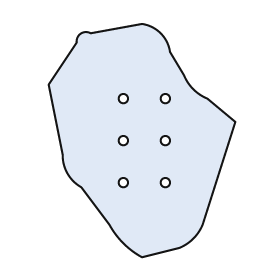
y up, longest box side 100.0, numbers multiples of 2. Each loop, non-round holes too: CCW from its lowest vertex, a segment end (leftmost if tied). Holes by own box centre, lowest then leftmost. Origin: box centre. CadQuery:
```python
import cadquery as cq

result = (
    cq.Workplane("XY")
    .moveTo(0.0, -50.0)
    .lineTo(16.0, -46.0)
    .threePointArc((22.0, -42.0), (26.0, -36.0))
    .lineTo(40.0, 8.0)
    .lineTo(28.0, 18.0)
    .threePointArc((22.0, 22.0), (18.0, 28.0))
    .lineTo(12.0, 38.0)
    .threePointArc((8.0, 46.0), (0.0, 50.0))
    .lineTo(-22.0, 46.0)
    .threePointArc((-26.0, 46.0), (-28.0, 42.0))
    .lineTo(-40.0, 24.0)
    .lineTo(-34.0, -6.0)
    .threePointArc((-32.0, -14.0), (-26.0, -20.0))
    .lineTo(-14.0, -36.0)
    .threePointArc((-8.0, -44.0), (0.0, -50.0))
    .close()
    .moveTo(-8.0, -18.0)
    .circle(2.0)
    .moveTo(10.0, -18.0)
    .circle(2.0)
    .moveTo(-8.0, 0.0)
    .circle(2.0)
    .moveTo(10.0, 0.0)
    .circle(2.0)
    .moveTo(-8.0, 18.0)
    .circle(2.0)
    .moveTo(10.0, 18.0)
    .circle(2.0)
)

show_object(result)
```